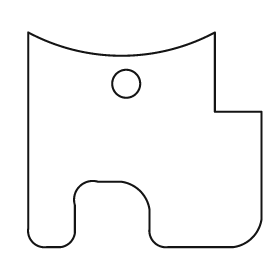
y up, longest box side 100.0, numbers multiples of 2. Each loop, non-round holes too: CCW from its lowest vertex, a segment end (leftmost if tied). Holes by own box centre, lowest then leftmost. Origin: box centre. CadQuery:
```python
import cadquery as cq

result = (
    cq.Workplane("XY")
    .moveTo(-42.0, -46.0)
    .lineTo(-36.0, -46.0)
    .threePointArc((-32.0, -44.0), (-30.0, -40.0))
    .lineTo(-30.0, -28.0)
    .threePointArc((-28.0, -20.0), (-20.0, -18.0))
    .lineTo(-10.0, -18.0)
    .threePointArc((-2.0, -22.0), (2.0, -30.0))
    .lineTo(2.0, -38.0)
    .threePointArc((4.0, -44.0), (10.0, -46.0))
    .lineTo(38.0, -46.0)
    .threePointArc((46.0, -42.0), (50.0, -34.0))
    .lineTo(50.0, 12.0)
    .lineTo(30.0, 12.0)
    .lineTo(30.0, 46.0)
    .threePointArc((-10.0, 36.0), (-50.0, 46.0))
    .lineTo(-50.0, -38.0)
    .threePointArc((-48.0, -44.0), (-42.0, -46.0))
    .close()
    .moveTo(-8.0, 24.0)
    .circle(6.0)
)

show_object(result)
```